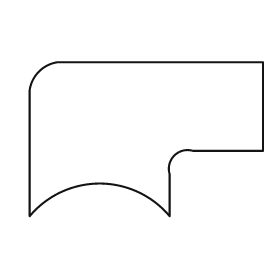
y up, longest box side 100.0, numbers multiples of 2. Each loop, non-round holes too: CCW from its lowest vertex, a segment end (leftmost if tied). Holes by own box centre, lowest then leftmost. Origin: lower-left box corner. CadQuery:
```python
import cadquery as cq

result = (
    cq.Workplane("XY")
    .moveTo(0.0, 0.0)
    .threePointArc((30.0, 14.0), (60.0, 0.0))
    .lineTo(60.0, 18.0)
    .threePointArc((62.0, 26.0), (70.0, 28.0))
    .lineTo(100.0, 28.0)
    .lineTo(100.0, 66.0)
    .lineTo(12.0, 66.0)
    .threePointArc((4.0, 62.0), (0.0, 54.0))
    .close()
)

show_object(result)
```